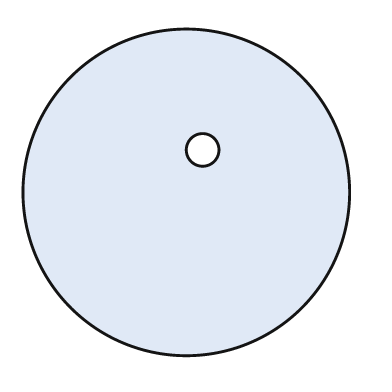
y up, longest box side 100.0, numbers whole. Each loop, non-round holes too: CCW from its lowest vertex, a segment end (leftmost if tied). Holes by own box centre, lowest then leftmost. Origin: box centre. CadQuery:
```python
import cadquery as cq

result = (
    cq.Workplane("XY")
    .moveTo(0.0, 0.0)
    .circle(50.0)
    .moveTo(5.0, 13.0)
    .circle(5.0)
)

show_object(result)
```